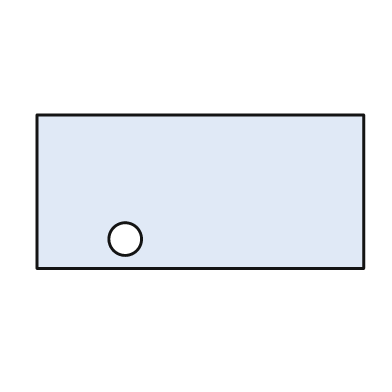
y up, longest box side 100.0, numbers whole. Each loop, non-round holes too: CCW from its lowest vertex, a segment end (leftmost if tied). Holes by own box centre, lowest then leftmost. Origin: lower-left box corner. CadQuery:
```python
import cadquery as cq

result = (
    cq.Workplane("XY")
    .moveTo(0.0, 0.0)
    .lineTo(100.0, 0.0)
    .lineTo(100.0, 47.0)
    .lineTo(0.0, 47.0)
    .close()
    .moveTo(27.0, 9.0)
    .circle(5.0)
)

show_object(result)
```